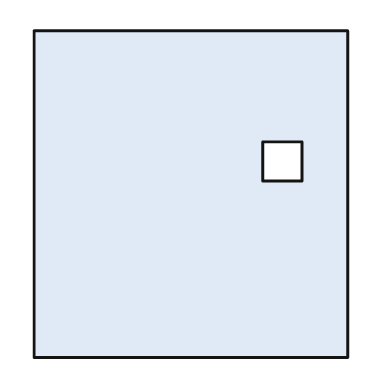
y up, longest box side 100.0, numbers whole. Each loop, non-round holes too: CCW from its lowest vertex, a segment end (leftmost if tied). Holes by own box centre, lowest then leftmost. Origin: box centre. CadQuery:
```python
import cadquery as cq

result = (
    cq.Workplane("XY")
    .moveTo(-48.0, -50.0)
    .lineTo(48.0, -50.0)
    .lineTo(48.0, 50.0)
    .lineTo(-48.0, 50.0)
    .close()
    .moveTo(22.0, 4.0)
    .lineTo(34.0, 4.0)
    .lineTo(34.0, 16.0)
    .lineTo(22.0, 16.0)
    .close()
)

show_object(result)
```